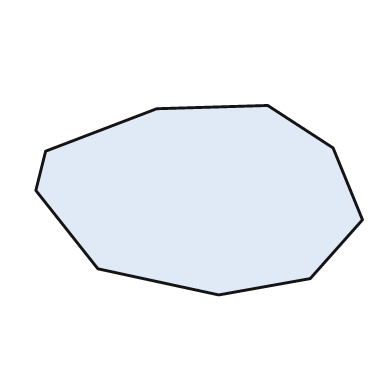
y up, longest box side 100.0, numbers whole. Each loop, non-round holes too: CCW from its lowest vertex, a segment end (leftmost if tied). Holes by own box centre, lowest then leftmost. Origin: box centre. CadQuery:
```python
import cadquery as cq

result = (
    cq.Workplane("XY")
    .moveTo(6.0, -29.0)
    .lineTo(34.0, -24.0)
    .lineTo(50.0, -6.0)
    .lineTo(41.0, 16.0)
    .lineTo(21.0, 29.0)
    .lineTo(-13.0, 28.0)
    .lineTo(-47.0, 15.0)
    .lineTo(-50.0, 3.0)
    .lineTo(-31.0, -21.0)
    .close()
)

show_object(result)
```